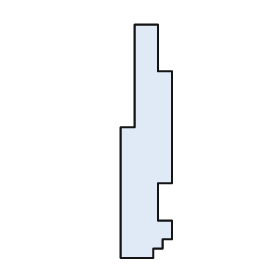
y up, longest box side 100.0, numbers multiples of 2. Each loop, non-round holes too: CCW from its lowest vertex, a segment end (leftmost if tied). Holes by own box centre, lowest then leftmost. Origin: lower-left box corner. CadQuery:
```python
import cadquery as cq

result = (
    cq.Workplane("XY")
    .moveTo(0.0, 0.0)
    .lineTo(14.0, 0.0)
    .lineTo(14.0, 4.0)
    .lineTo(18.0, 4.0)
    .lineTo(18.0, 8.0)
    .lineTo(22.0, 8.0)
    .lineTo(22.0, 16.0)
    .lineTo(16.0, 16.0)
    .lineTo(16.0, 32.0)
    .lineTo(22.0, 32.0)
    .lineTo(22.0, 80.0)
    .lineTo(16.0, 80.0)
    .lineTo(16.0, 100.0)
    .lineTo(6.0, 100.0)
    .lineTo(6.0, 56.0)
    .lineTo(0.0, 56.0)
    .close()
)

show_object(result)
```